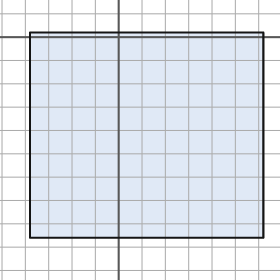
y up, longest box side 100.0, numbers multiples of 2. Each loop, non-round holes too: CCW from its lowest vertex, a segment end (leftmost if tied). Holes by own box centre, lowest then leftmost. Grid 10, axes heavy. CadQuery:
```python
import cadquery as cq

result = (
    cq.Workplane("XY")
    .moveTo(-38.0, -86.0)
    .lineTo(62.0, -86.0)
    .lineTo(62.0, 2.0)
    .lineTo(-38.0, 2.0)
    .close()
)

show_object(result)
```